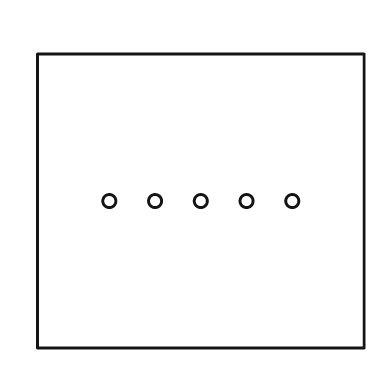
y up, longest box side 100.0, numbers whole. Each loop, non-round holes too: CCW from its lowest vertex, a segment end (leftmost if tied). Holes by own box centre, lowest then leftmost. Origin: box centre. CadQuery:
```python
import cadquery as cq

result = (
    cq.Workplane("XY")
    .moveTo(-50.0, -45.0)
    .lineTo(50.0, -45.0)
    .lineTo(50.0, 45.0)
    .lineTo(-50.0, 45.0)
    .close()
    .moveTo(-28.0, 0.0)
    .circle(2.0)
    .moveTo(-14.0, 0.0)
    .circle(2.0)
    .moveTo(0.0, 0.0)
    .circle(2.0)
    .moveTo(14.0, 0.0)
    .circle(2.0)
    .moveTo(28.0, 0.0)
    .circle(2.0)
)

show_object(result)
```